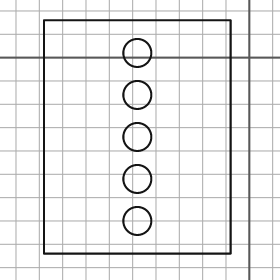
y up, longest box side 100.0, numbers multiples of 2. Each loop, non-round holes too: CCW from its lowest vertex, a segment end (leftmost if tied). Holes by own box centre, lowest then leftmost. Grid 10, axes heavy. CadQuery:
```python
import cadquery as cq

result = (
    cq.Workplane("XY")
    .moveTo(-88.0, -84.0)
    .lineTo(-8.0, -84.0)
    .lineTo(-8.0, 16.0)
    .lineTo(-88.0, 16.0)
    .close()
    .moveTo(-48.0, -70.0)
    .circle(6.0)
    .moveTo(-48.0, -52.0)
    .circle(6.0)
    .moveTo(-48.0, -34.0)
    .circle(6.0)
    .moveTo(-48.0, -16.0)
    .circle(6.0)
    .moveTo(-48.0, 2.0)
    .circle(6.0)
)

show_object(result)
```